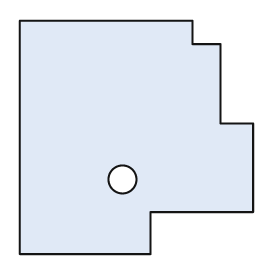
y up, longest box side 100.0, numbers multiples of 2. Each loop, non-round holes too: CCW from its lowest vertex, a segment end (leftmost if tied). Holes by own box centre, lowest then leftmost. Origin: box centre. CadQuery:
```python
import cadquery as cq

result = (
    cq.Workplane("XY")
    .moveTo(-50.0, -50.0)
    .lineTo(6.0, -50.0)
    .lineTo(6.0, -32.0)
    .lineTo(50.0, -32.0)
    .lineTo(50.0, 6.0)
    .lineTo(36.0, 6.0)
    .lineTo(36.0, 40.0)
    .lineTo(24.0, 40.0)
    .lineTo(24.0, 50.0)
    .lineTo(-50.0, 50.0)
    .close()
    .moveTo(-6.0, -18.0)
    .circle(6.0)
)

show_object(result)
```